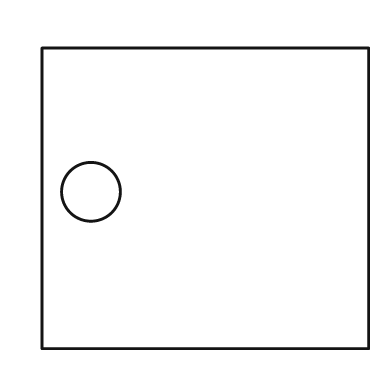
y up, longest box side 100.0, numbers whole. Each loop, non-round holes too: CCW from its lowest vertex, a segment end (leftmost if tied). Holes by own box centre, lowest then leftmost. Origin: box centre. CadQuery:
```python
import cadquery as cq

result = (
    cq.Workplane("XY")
    .moveTo(-50.0, -46.0)
    .lineTo(50.0, -46.0)
    .lineTo(50.0, 46.0)
    .lineTo(-50.0, 46.0)
    .close()
    .moveTo(-35.0, 2.0)
    .circle(9.0)
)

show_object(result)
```